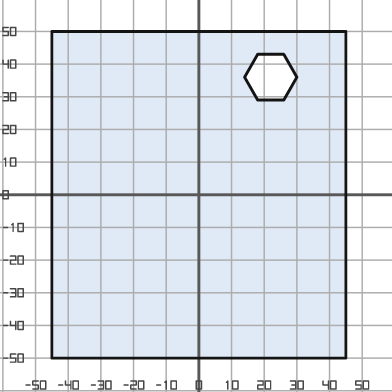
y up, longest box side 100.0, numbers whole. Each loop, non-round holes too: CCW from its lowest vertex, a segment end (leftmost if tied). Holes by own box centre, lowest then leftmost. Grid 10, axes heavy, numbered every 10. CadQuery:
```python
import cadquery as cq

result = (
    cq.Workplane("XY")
    .moveTo(-45.0, -50.0)
    .lineTo(45.0, -50.0)
    .lineTo(45.0, 50.0)
    .lineTo(-45.0, 50.0)
    .close()
    .moveTo(18.0, 29.0)
    .lineTo(26.0, 29.0)
    .lineTo(30.0, 36.0)
    .lineTo(26.0, 43.0)
    .lineTo(18.0, 43.0)
    .lineTo(14.0, 36.0)
    .close()
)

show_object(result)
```